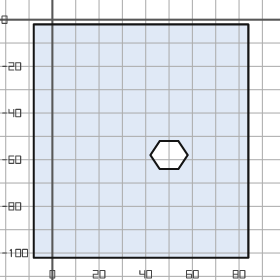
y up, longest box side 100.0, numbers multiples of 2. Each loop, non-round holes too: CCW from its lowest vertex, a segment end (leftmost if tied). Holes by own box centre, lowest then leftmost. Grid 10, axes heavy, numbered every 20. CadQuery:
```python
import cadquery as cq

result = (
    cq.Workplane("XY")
    .moveTo(-8.0, -102.0)
    .lineTo(84.0, -102.0)
    .lineTo(84.0, -2.0)
    .lineTo(-8.0, -2.0)
    .close()
    .moveTo(46.0, -64.0)
    .lineTo(54.0, -64.0)
    .lineTo(58.0, -58.0)
    .lineTo(54.0, -52.0)
    .lineTo(46.0, -52.0)
    .lineTo(42.0, -58.0)
    .close()
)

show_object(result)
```